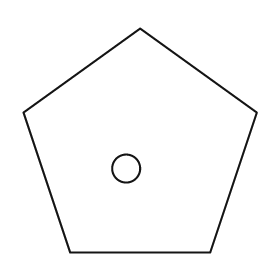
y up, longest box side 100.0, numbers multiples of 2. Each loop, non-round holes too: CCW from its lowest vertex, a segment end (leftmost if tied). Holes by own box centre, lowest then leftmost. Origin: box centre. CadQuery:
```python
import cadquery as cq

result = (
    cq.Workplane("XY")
    .moveTo(-30.0, -48.0)
    .lineTo(30.0, -48.0)
    .lineTo(50.0, 12.0)
    .lineTo(0.0, 48.0)
    .lineTo(-50.0, 12.0)
    .close()
    .moveTo(-6.0, -12.0)
    .circle(6.0)
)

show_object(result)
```